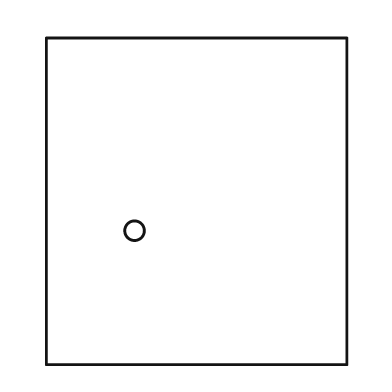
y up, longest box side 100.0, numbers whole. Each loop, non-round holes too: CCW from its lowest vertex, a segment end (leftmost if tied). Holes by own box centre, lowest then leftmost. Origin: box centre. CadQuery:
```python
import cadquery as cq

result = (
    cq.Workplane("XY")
    .moveTo(-46.0, -50.0)
    .lineTo(46.0, -50.0)
    .lineTo(46.0, 50.0)
    .lineTo(-46.0, 50.0)
    .close()
    .moveTo(-19.0, -9.0)
    .circle(3.0)
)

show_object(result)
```